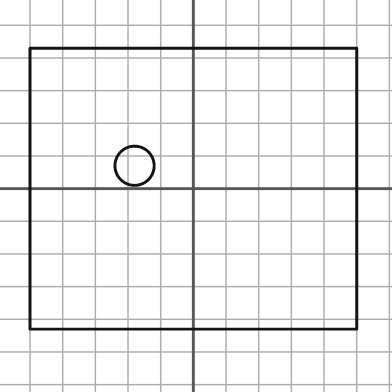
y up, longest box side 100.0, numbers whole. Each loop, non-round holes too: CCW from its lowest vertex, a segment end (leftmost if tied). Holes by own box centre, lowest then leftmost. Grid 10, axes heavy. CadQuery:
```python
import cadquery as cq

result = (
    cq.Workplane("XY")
    .moveTo(-50.0, -43.0)
    .lineTo(50.0, -43.0)
    .lineTo(50.0, 43.0)
    .lineTo(-50.0, 43.0)
    .close()
    .moveTo(-18.0, 7.0)
    .circle(6.0)
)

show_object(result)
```